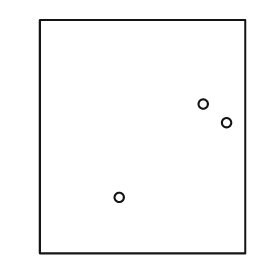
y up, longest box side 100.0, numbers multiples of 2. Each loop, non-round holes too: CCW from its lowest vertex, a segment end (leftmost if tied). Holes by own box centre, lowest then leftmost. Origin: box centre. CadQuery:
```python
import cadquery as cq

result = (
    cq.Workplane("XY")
    .moveTo(-44.0, -50.0)
    .lineTo(44.0, -50.0)
    .lineTo(44.0, 50.0)
    .lineTo(-44.0, 50.0)
    .close()
    .moveTo(-10.0, -26.0)
    .circle(2.0)
    .moveTo(36.0, 6.0)
    .circle(2.0)
    .moveTo(26.0, 14.0)
    .circle(2.0)
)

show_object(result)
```